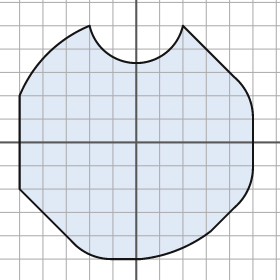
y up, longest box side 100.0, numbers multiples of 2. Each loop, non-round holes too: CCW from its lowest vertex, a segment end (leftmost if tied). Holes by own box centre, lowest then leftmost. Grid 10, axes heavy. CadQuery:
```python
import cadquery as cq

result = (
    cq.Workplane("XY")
    .moveTo(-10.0, -50.0)
    .lineTo(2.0, -50.0)
    .threePointArc((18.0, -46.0), (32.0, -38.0))
    .lineTo(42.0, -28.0)
    .threePointArc((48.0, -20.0), (50.0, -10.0))
    .lineTo(50.0, 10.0)
    .threePointArc((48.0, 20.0), (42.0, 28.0))
    .lineTo(20.0, 50.0)
    .threePointArc((0.0, 34.0), (-20.0, 50.0))
    .threePointArc((-38.0, 38.0), (-50.0, 20.0))
    .lineTo(-50.0, -20.0)
    .lineTo(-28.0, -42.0)
    .threePointArc((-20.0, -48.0), (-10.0, -50.0))
    .close()
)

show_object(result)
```